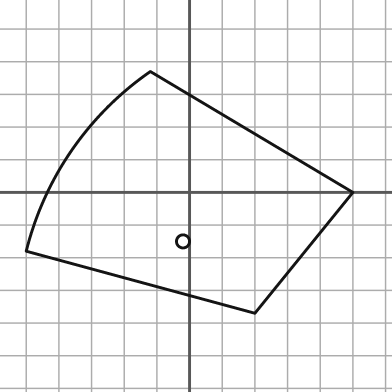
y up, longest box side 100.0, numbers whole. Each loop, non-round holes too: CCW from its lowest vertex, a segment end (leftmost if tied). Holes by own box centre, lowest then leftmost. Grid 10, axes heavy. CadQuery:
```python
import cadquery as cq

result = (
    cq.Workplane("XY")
    .moveTo(20.0, -37.0)
    .lineTo(50.0, 0.0)
    .lineTo(-12.0, 37.0)
    .threePointArc((-36.0, 13.0), (-50.0, -18.0))
    .close()
    .moveTo(-2.0, -15.0)
    .circle(2.0)
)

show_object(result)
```